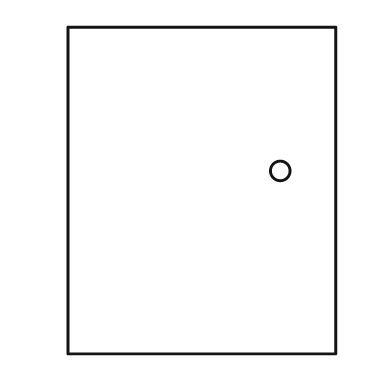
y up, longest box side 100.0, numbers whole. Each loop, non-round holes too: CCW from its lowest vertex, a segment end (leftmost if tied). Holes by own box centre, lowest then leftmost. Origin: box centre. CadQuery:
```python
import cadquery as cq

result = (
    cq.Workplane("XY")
    .moveTo(-41.0, -50.0)
    .lineTo(41.0, -50.0)
    .lineTo(41.0, 50.0)
    .lineTo(-41.0, 50.0)
    .close()
    .moveTo(24.0, 6.0)
    .circle(3.0)
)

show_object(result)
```